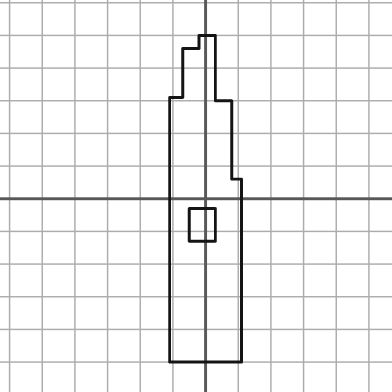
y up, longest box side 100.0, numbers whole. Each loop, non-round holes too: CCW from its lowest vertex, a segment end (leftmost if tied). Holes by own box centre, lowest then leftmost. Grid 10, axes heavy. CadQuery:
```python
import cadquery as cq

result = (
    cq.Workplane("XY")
    .moveTo(-11.0, -50.0)
    .lineTo(11.0, -50.0)
    .lineTo(11.0, 6.0)
    .lineTo(8.0, 6.0)
    .lineTo(8.0, 30.0)
    .lineTo(3.0, 30.0)
    .lineTo(3.0, 50.0)
    .lineTo(-2.0, 50.0)
    .lineTo(-2.0, 46.0)
    .lineTo(-7.0, 46.0)
    .lineTo(-7.0, 31.0)
    .lineTo(-11.0, 31.0)
    .close()
    .moveTo(-5.0, -13.0)
    .lineTo(3.0, -13.0)
    .lineTo(3.0, -3.0)
    .lineTo(-5.0, -3.0)
    .close()
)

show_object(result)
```